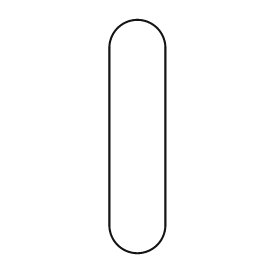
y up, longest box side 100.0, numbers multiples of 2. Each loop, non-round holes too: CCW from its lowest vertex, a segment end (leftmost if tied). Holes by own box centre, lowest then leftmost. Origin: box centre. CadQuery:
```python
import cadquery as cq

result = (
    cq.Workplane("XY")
    .moveTo(-12.0, -38.0)
    .threePointArc((0.0, -50.0), (12.0, -38.0))
    .lineTo(12.0, 38.0)
    .threePointArc((0.0, 50.0), (-12.0, 38.0))
    .close()
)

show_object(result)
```